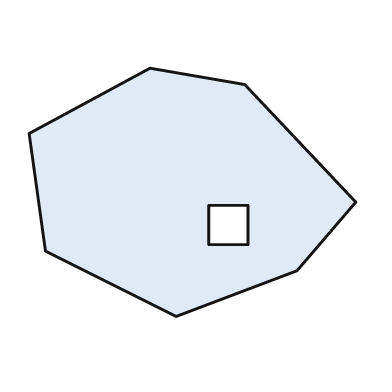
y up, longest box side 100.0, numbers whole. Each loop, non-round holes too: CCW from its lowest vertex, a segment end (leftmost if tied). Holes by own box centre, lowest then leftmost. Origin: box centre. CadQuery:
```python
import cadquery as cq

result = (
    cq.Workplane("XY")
    .moveTo(-5.0, -38.0)
    .lineTo(32.0, -24.0)
    .lineTo(50.0, -3.0)
    .lineTo(16.0, 33.0)
    .lineTo(-13.0, 38.0)
    .lineTo(-50.0, 18.0)
    .lineTo(-45.0, -18.0)
    .close()
    .moveTo(5.0, -16.0)
    .lineTo(17.0, -16.0)
    .lineTo(17.0, -4.0)
    .lineTo(5.0, -4.0)
    .close()
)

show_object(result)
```